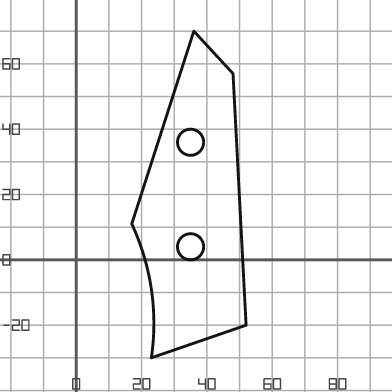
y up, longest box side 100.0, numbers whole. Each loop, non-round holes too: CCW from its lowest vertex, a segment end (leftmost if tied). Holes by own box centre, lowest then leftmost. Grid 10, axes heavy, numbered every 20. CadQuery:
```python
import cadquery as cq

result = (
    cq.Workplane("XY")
    .moveTo(23.0, -30.0)
    .lineTo(52.0, -20.0)
    .lineTo(48.0, 57.0)
    .lineTo(36.0, 70.0)
    .lineTo(17.0, 11.0)
    .threePointArc((23.0, -9.0), (23.0, -30.0))
    .close()
    .moveTo(35.0, 4.0)
    .circle(4.0)
    .moveTo(35.0, 36.0)
    .circle(4.0)
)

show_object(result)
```